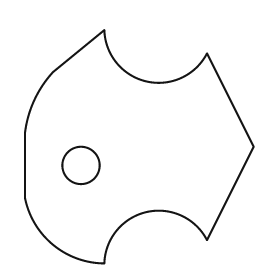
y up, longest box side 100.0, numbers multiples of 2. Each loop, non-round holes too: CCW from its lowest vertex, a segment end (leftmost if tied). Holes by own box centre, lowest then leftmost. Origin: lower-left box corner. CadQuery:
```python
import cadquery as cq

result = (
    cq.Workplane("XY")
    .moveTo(34.0, 0.0)
    .threePointArc((52.0, 22.0), (78.0, 10.0))
    .lineTo(98.0, 50.0)
    .lineTo(78.0, 90.0)
    .threePointArc((52.0, 78.0), (34.0, 100.0))
    .lineTo(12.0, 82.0)
    .threePointArc((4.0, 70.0), (0.0, 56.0))
    .lineTo(0.0, 28.0)
    .threePointArc((12.0, 8.0), (34.0, 0.0))
    .close()
    .moveTo(24.0, 42.0)
    .circle(8.0)
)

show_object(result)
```